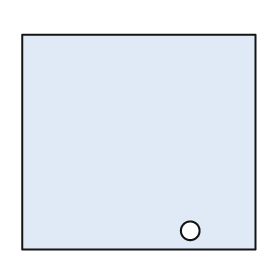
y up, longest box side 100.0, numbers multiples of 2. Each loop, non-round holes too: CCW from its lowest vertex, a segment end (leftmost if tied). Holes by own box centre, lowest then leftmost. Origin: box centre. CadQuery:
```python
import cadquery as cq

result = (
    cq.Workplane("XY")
    .moveTo(-50.0, -46.0)
    .lineTo(50.0, -46.0)
    .lineTo(50.0, 46.0)
    .lineTo(-50.0, 46.0)
    .close()
    .moveTo(22.0, -38.0)
    .circle(4.0)
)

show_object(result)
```